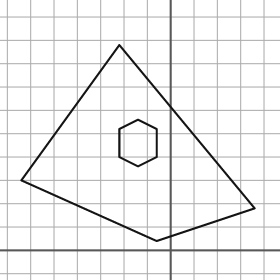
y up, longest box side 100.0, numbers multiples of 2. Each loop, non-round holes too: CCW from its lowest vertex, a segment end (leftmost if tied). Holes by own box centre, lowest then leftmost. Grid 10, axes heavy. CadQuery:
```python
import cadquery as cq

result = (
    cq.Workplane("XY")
    .moveTo(-6.0, 4.0)
    .lineTo(36.0, 18.0)
    .lineTo(-22.0, 88.0)
    .lineTo(-64.0, 30.0)
    .close()
    .moveTo(-14.0, 36.0)
    .lineTo(-6.0, 40.0)
    .lineTo(-6.0, 52.0)
    .lineTo(-14.0, 56.0)
    .lineTo(-22.0, 52.0)
    .lineTo(-22.0, 40.0)
    .close()
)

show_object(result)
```